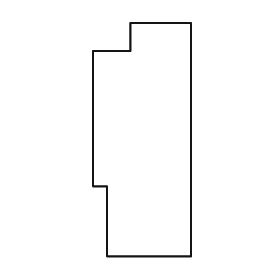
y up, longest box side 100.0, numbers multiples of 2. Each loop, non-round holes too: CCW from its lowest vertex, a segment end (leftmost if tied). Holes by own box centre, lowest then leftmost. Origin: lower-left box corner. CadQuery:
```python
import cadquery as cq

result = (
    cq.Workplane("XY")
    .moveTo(6.0, 0.0)
    .lineTo(42.0, 0.0)
    .lineTo(42.0, 100.0)
    .lineTo(16.0, 100.0)
    .lineTo(16.0, 88.0)
    .lineTo(0.0, 88.0)
    .lineTo(0.0, 30.0)
    .lineTo(6.0, 30.0)
    .close()
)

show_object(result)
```